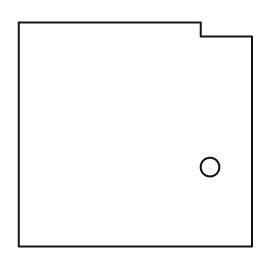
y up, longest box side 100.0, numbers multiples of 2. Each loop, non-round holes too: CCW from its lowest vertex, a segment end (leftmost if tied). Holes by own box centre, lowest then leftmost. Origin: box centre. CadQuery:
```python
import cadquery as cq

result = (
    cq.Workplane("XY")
    .moveTo(-50.0, -48.0)
    .lineTo(50.0, -48.0)
    .lineTo(50.0, 42.0)
    .lineTo(28.0, 42.0)
    .lineTo(28.0, 48.0)
    .lineTo(-50.0, 48.0)
    .close()
    .moveTo(32.0, -14.0)
    .circle(4.0)
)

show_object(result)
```